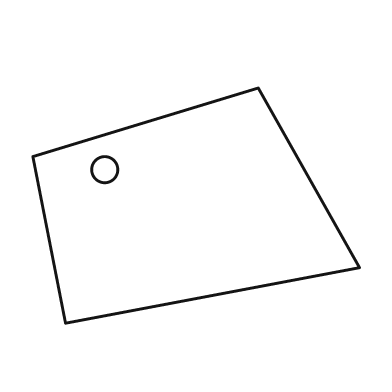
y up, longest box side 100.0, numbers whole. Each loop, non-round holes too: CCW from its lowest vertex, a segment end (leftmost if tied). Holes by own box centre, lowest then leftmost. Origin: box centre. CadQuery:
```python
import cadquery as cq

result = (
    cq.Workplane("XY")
    .moveTo(-40.0, -36.0)
    .lineTo(50.0, -19.0)
    .lineTo(19.0, 36.0)
    .lineTo(-50.0, 15.0)
    .close()
    .moveTo(-28.0, 11.0)
    .circle(4.0)
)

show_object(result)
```